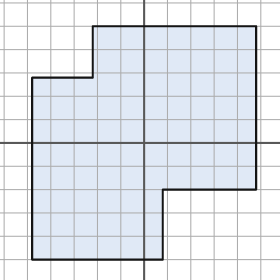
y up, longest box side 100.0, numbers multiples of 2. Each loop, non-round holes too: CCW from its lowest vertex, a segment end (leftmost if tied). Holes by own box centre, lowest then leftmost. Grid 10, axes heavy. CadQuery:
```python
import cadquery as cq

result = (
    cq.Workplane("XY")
    .moveTo(-48.0, -50.0)
    .lineTo(8.0, -50.0)
    .lineTo(8.0, -20.0)
    .lineTo(48.0, -20.0)
    .lineTo(48.0, 50.0)
    .lineTo(-22.0, 50.0)
    .lineTo(-22.0, 28.0)
    .lineTo(-48.0, 28.0)
    .close()
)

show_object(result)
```